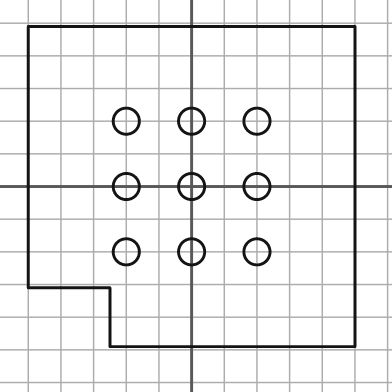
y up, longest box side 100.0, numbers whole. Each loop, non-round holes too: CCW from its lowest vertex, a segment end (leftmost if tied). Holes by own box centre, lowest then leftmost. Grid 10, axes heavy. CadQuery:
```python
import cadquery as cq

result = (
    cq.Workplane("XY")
    .moveTo(-25.0, -49.0)
    .lineTo(50.0, -49.0)
    .lineTo(50.0, 49.0)
    .lineTo(-50.0, 49.0)
    .lineTo(-50.0, -31.0)
    .lineTo(-25.0, -31.0)
    .close()
    .moveTo(-20.0, -20.0)
    .circle(4.0)
    .moveTo(0.0, -20.0)
    .circle(4.0)
    .moveTo(20.0, -20.0)
    .circle(4.0)
    .moveTo(-20.0, 0.0)
    .circle(4.0)
    .moveTo(0.0, 0.0)
    .circle(4.0)
    .moveTo(20.0, 0.0)
    .circle(4.0)
    .moveTo(-20.0, 20.0)
    .circle(4.0)
    .moveTo(0.0, 20.0)
    .circle(4.0)
    .moveTo(20.0, 20.0)
    .circle(4.0)
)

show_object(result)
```